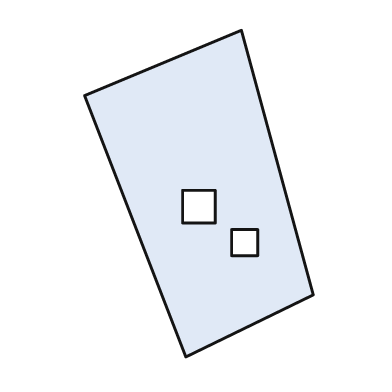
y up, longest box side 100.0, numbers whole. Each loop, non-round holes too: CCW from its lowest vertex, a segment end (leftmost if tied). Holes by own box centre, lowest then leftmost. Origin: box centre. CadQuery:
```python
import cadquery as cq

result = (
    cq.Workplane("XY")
    .moveTo(-4.0, -50.0)
    .lineTo(35.0, -31.0)
    .lineTo(13.0, 50.0)
    .lineTo(-35.0, 30.0)
    .close()
    .moveTo(10.0, -19.0)
    .lineTo(18.0, -19.0)
    .lineTo(18.0, -11.0)
    .lineTo(10.0, -11.0)
    .close()
    .moveTo(-5.0, -9.0)
    .lineTo(5.0, -9.0)
    .lineTo(5.0, 1.0)
    .lineTo(-5.0, 1.0)
    .close()
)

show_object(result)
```